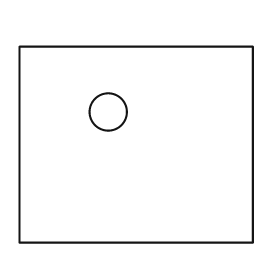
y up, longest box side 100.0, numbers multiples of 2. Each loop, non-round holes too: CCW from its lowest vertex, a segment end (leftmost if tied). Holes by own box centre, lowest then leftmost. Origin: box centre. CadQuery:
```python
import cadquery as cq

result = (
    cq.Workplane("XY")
    .moveTo(-50.0, -42.0)
    .lineTo(50.0, -42.0)
    .lineTo(50.0, 42.0)
    .lineTo(-50.0, 42.0)
    .close()
    .moveTo(-12.0, 14.0)
    .circle(8.0)
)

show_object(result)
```